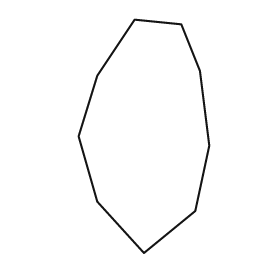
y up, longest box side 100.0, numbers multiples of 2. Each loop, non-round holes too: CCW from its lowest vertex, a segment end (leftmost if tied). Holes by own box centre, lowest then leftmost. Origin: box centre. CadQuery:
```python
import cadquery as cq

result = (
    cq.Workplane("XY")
    .moveTo(0.0, -50.0)
    .lineTo(22.0, -32.0)
    .lineTo(28.0, -4.0)
    .lineTo(24.0, 28.0)
    .lineTo(16.0, 48.0)
    .lineTo(-4.0, 50.0)
    .lineTo(-20.0, 26.0)
    .lineTo(-28.0, 0.0)
    .lineTo(-20.0, -28.0)
    .close()
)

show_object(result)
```